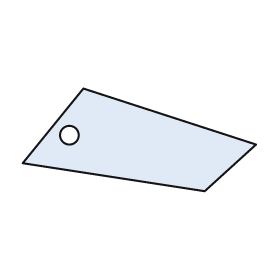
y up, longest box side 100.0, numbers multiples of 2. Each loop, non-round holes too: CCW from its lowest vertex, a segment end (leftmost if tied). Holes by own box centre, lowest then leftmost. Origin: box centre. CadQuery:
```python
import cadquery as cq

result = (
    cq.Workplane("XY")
    .moveTo(28.0, -22.0)
    .lineTo(50.0, -2.0)
    .lineTo(-24.0, 22.0)
    .lineTo(-50.0, -10.0)
    .close()
    .moveTo(-30.0, 2.0)
    .circle(4.0)
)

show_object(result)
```